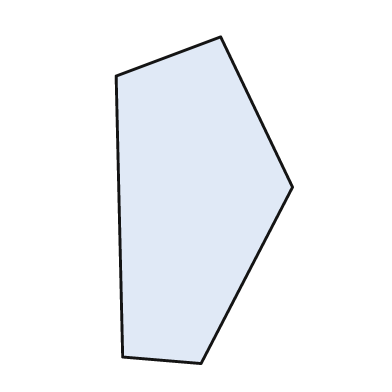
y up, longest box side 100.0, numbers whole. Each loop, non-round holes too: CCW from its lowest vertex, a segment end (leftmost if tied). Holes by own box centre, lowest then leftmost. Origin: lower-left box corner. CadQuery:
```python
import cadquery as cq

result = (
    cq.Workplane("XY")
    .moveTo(26.0, 0.0)
    .lineTo(54.0, 54.0)
    .lineTo(32.0, 100.0)
    .lineTo(0.0, 88.0)
    .lineTo(2.0, 2.0)
    .close()
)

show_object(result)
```